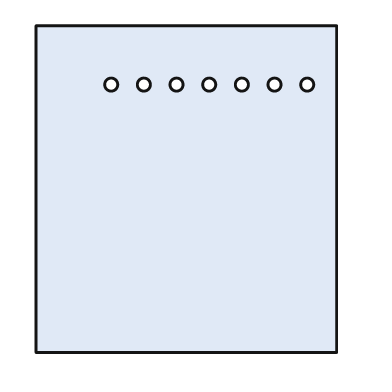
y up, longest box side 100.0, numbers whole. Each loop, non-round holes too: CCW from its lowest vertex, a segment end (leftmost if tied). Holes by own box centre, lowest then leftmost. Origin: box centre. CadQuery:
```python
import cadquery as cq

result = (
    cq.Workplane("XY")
    .moveTo(-46.0, -50.0)
    .lineTo(46.0, -50.0)
    .lineTo(46.0, 50.0)
    .lineTo(-46.0, 50.0)
    .close()
    .moveTo(-23.0, 32.0)
    .circle(2.0)
    .moveTo(-13.0, 32.0)
    .circle(2.0)
    .moveTo(-3.0, 32.0)
    .circle(2.0)
    .moveTo(7.0, 32.0)
    .circle(2.0)
    .moveTo(17.0, 32.0)
    .circle(2.0)
    .moveTo(27.0, 32.0)
    .circle(2.0)
    .moveTo(37.0, 32.0)
    .circle(2.0)
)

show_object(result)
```